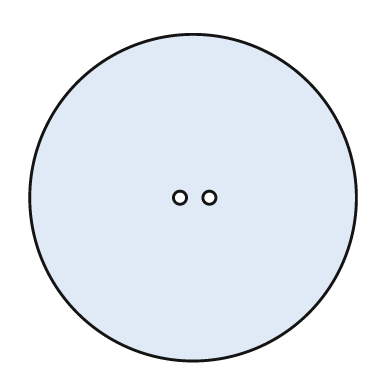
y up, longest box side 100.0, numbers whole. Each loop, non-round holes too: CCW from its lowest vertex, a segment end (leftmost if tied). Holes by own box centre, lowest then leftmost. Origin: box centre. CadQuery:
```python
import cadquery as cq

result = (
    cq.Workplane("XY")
    .moveTo(0.0, 0.0)
    .circle(50.0)
    .moveTo(-4.0, 0.0)
    .circle(2.0)
    .moveTo(5.0, 0.0)
    .circle(2.0)
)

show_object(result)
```